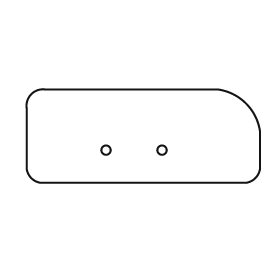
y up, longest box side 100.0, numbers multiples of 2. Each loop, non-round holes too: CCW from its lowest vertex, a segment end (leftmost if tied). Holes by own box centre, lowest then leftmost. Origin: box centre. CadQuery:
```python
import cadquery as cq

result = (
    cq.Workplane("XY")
    .moveTo(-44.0, -20.0)
    .lineTo(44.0, -20.0)
    .threePointArc((48.0, -18.0), (50.0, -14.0))
    .lineTo(50.0, 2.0)
    .threePointArc((44.0, 14.0), (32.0, 20.0))
    .lineTo(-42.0, 20.0)
    .threePointArc((-48.0, 18.0), (-50.0, 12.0))
    .lineTo(-50.0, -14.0)
    .threePointArc((-48.0, -18.0), (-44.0, -20.0))
    .close()
    .moveTo(-16.0, -6.0)
    .circle(2.0)
    .moveTo(8.0, -6.0)
    .circle(2.0)
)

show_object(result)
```